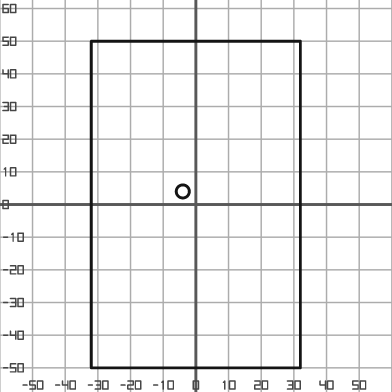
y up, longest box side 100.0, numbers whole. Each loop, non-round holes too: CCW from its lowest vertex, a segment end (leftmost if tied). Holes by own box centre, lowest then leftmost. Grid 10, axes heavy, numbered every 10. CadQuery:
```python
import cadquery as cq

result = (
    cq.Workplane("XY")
    .moveTo(-32.0, -50.0)
    .lineTo(32.0, -50.0)
    .lineTo(32.0, 50.0)
    .lineTo(-32.0, 50.0)
    .close()
    .moveTo(-4.0, 4.0)
    .circle(2.0)
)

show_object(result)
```